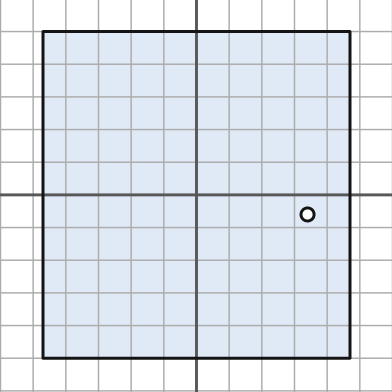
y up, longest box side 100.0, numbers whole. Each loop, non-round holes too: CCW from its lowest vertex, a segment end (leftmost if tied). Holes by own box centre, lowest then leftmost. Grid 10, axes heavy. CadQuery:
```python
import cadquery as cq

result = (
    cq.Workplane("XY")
    .moveTo(-47.0, -50.0)
    .lineTo(47.0, -50.0)
    .lineTo(47.0, 50.0)
    .lineTo(-47.0, 50.0)
    .close()
    .moveTo(34.0, -6.0)
    .circle(2.0)
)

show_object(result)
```